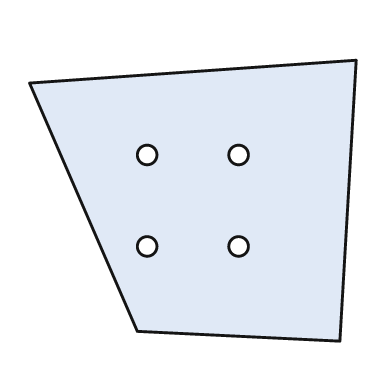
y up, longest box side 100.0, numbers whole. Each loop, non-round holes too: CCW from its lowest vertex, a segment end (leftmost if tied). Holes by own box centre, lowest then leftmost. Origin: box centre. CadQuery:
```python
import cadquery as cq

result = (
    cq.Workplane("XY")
    .moveTo(45.0, -43.0)
    .lineTo(50.0, 43.0)
    .lineTo(-50.0, 36.0)
    .lineTo(-17.0, -40.0)
    .close()
    .moveTo(-14.0, -14.0)
    .circle(3.0)
    .moveTo(14.0, -14.0)
    .circle(3.0)
    .moveTo(-14.0, 14.0)
    .circle(3.0)
    .moveTo(14.0, 14.0)
    .circle(3.0)
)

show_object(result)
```